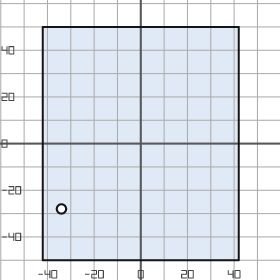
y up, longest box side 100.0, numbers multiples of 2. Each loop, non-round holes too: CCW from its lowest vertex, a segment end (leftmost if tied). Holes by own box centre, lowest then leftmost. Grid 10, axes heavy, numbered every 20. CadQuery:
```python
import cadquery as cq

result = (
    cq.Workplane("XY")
    .moveTo(-42.0, -50.0)
    .lineTo(42.0, -50.0)
    .lineTo(42.0, 50.0)
    .lineTo(-42.0, 50.0)
    .close()
    .moveTo(-34.0, -28.0)
    .circle(2.0)
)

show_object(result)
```